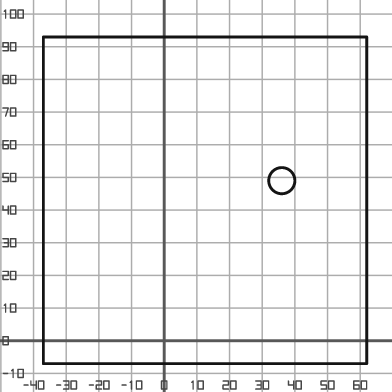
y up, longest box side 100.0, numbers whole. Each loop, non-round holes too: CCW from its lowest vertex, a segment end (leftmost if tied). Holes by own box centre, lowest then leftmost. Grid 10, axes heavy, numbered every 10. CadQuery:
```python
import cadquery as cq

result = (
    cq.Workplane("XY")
    .moveTo(-37.0, -7.0)
    .lineTo(62.0, -7.0)
    .lineTo(62.0, 93.0)
    .lineTo(-37.0, 93.0)
    .close()
    .moveTo(36.0, 49.0)
    .circle(4.0)
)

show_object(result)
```